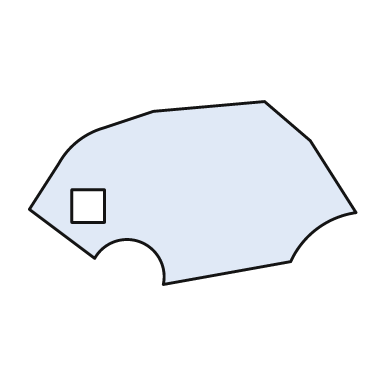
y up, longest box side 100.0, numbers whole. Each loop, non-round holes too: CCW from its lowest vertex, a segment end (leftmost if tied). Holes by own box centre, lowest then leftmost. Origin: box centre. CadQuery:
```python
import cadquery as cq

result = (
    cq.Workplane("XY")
    .moveTo(-9.0, -28.0)
    .lineTo(30.0, -21.0)
    .threePointArc((38.0, -11.0), (50.0, -6.0))
    .lineTo(36.0, 16.0)
    .lineTo(22.0, 28.0)
    .lineTo(-12.0, 25.0)
    .lineTo(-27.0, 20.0)
    .threePointArc((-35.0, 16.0), (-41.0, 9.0))
    .lineTo(-50.0, -5.0)
    .lineTo(-30.0, -20.0)
    .threePointArc((-16.0, -15.0), (-9.0, -28.0))
    .close()
    .moveTo(-37.0, -9.0)
    .lineTo(-27.0, -9.0)
    .lineTo(-27.0, 1.0)
    .lineTo(-37.0, 1.0)
    .close()
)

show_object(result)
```